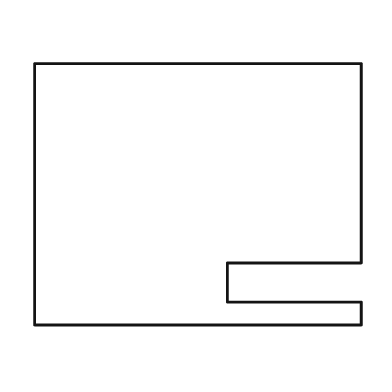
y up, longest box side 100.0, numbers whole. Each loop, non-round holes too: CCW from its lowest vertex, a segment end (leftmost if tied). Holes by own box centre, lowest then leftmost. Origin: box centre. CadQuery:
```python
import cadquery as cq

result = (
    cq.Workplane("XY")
    .moveTo(-50.0, -40.0)
    .lineTo(50.0, -40.0)
    .lineTo(50.0, -33.0)
    .lineTo(9.0, -33.0)
    .lineTo(9.0, -21.0)
    .lineTo(50.0, -21.0)
    .lineTo(50.0, 40.0)
    .lineTo(-50.0, 40.0)
    .close()
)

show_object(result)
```